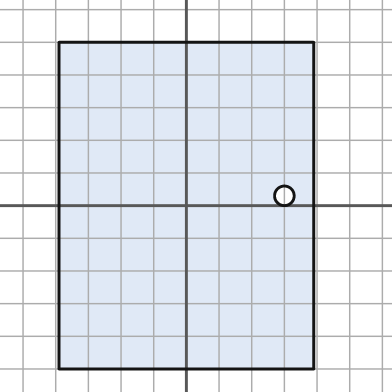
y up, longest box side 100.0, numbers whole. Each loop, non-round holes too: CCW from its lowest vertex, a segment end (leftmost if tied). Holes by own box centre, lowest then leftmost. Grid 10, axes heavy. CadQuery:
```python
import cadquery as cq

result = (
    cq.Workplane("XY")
    .moveTo(-39.0, -50.0)
    .lineTo(39.0, -50.0)
    .lineTo(39.0, 50.0)
    .lineTo(-39.0, 50.0)
    .close()
    .moveTo(30.0, 3.0)
    .circle(3.0)
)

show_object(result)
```